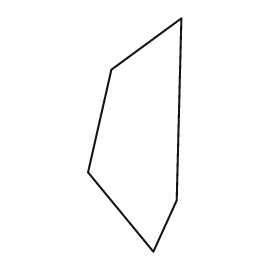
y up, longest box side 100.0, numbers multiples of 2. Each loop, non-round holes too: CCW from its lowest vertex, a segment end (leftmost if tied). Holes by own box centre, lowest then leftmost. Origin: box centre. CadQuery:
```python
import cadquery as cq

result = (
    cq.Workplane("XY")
    .moveTo(8.0, -50.0)
    .lineTo(18.0, -28.0)
    .lineTo(20.0, 50.0)
    .lineTo(-10.0, 28.0)
    .lineTo(-20.0, -16.0)
    .close()
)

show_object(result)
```